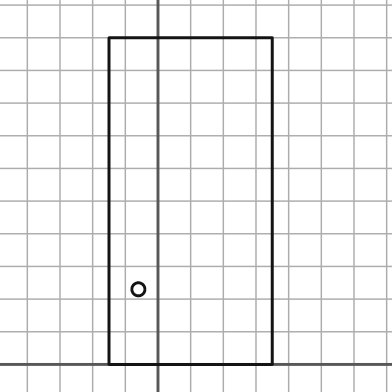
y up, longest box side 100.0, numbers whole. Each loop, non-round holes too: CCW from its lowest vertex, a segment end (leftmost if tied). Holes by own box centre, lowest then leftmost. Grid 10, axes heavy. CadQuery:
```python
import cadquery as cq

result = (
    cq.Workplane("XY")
    .moveTo(-15.0, 0.0)
    .lineTo(35.0, 0.0)
    .lineTo(35.0, 100.0)
    .lineTo(-15.0, 100.0)
    .close()
    .moveTo(-6.0, 23.0)
    .circle(2.0)
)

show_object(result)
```